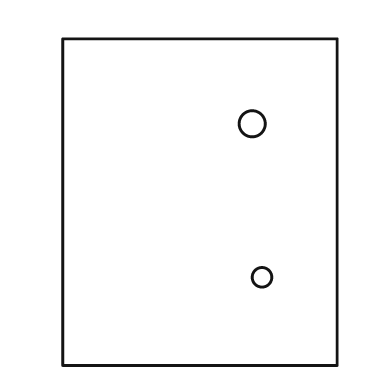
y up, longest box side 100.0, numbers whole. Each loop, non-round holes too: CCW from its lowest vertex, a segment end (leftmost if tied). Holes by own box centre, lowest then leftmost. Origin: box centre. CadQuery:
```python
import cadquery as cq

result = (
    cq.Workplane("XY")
    .moveTo(-42.0, -50.0)
    .lineTo(42.0, -50.0)
    .lineTo(42.0, 50.0)
    .lineTo(-42.0, 50.0)
    .close()
    .moveTo(19.0, -23.0)
    .circle(3.0)
    .moveTo(16.0, 24.0)
    .circle(4.0)
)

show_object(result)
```